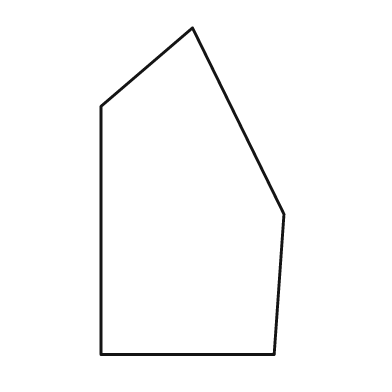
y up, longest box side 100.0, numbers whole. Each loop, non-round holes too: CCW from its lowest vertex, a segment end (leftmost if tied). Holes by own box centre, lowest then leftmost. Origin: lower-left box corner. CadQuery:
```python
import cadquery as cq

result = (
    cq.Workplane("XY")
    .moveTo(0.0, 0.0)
    .lineTo(53.0, 0.0)
    .lineTo(56.0, 43.0)
    .lineTo(28.0, 100.0)
    .lineTo(0.0, 76.0)
    .close()
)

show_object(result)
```